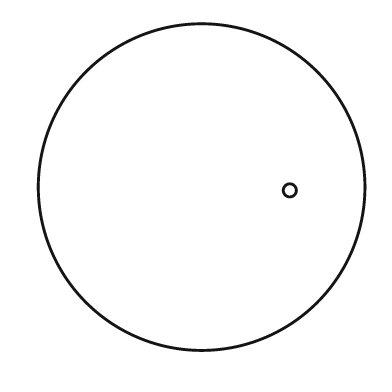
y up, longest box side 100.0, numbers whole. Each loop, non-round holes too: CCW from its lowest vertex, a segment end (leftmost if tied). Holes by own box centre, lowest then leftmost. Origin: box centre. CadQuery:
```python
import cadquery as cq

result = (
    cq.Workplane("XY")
    .moveTo(0.0, 0.0)
    .circle(50.0)
    .moveTo(27.0, -1.0)
    .circle(2.0)
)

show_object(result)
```